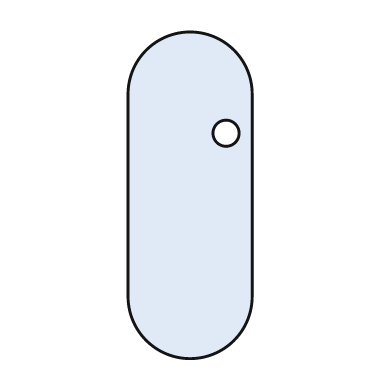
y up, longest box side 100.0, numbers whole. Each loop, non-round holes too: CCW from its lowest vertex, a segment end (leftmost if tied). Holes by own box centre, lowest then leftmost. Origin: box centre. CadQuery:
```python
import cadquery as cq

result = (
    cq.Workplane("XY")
    .moveTo(-19.0, -31.0)
    .threePointArc((0.0, -50.0), (19.0, -31.0))
    .lineTo(19.0, 31.0)
    .threePointArc((0.0, 50.0), (-19.0, 31.0))
    .close()
    .moveTo(11.0, 19.0)
    .circle(4.0)
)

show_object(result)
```